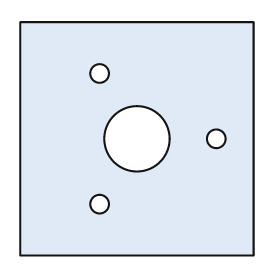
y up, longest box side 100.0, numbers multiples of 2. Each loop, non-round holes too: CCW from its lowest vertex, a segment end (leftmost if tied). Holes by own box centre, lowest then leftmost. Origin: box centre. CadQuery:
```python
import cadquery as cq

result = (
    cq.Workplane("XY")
    .moveTo(-50.0, -50.0)
    .lineTo(50.0, -50.0)
    .lineTo(50.0, 50.0)
    .lineTo(-50.0, 50.0)
    .close()
    .moveTo(-16.0, -28.0)
    .circle(4.0)
    .moveTo(0.0, 0.0)
    .circle(14.0)
    .moveTo(34.0, 0.0)
    .circle(4.0)
    .moveTo(-16.0, 28.0)
    .circle(4.0)
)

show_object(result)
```